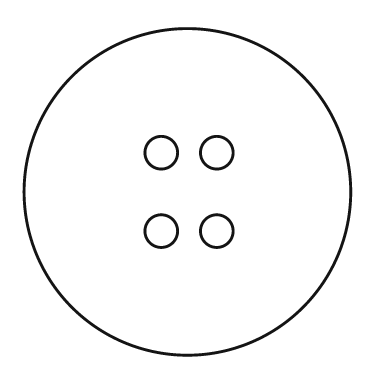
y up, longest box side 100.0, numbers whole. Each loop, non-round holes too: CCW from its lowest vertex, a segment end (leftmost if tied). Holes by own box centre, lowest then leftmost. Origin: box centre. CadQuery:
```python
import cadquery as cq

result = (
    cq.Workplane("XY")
    .moveTo(0.0, 0.0)
    .circle(50.0)
    .moveTo(-8.0, -12.0)
    .circle(5.0)
    .moveTo(9.0, -12.0)
    .circle(5.0)
    .moveTo(-8.0, 12.0)
    .circle(5.0)
    .moveTo(9.0, 12.0)
    .circle(5.0)
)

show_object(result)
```